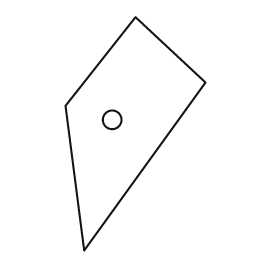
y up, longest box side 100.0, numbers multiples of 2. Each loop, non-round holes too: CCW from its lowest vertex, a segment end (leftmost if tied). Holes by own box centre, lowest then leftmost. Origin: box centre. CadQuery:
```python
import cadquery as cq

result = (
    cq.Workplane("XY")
    .moveTo(-22.0, -50.0)
    .lineTo(30.0, 22.0)
    .lineTo(0.0, 50.0)
    .lineTo(-30.0, 12.0)
    .close()
    .moveTo(-10.0, 6.0)
    .circle(4.0)
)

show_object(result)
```